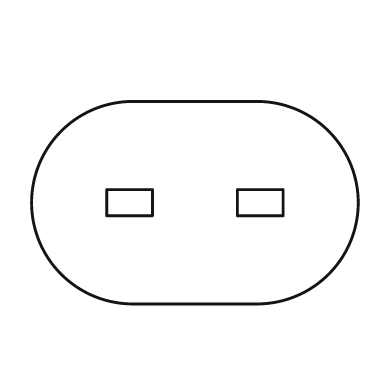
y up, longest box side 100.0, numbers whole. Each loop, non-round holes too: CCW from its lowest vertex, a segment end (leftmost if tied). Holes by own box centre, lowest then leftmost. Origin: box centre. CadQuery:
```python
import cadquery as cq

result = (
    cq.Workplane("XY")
    .moveTo(-19.0, -31.0)
    .lineTo(19.0, -31.0)
    .threePointArc((50.0, 0.0), (19.0, 31.0))
    .lineTo(-19.0, 31.0)
    .threePointArc((-50.0, 0.0), (-19.0, -31.0))
    .close()
    .moveTo(-27.0, -4.0)
    .lineTo(-13.0, -4.0)
    .lineTo(-13.0, 4.0)
    .lineTo(-27.0, 4.0)
    .close()
    .moveTo(13.0, -4.0)
    .lineTo(27.0, -4.0)
    .lineTo(27.0, 4.0)
    .lineTo(13.0, 4.0)
    .close()
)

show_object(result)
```